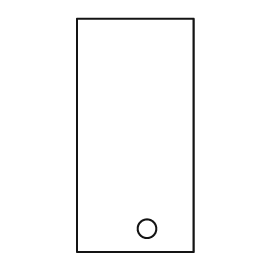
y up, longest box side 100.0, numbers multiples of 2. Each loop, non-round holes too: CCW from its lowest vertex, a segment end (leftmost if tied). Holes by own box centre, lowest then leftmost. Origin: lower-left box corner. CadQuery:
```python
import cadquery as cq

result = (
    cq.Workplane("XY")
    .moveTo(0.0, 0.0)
    .lineTo(50.0, 0.0)
    .lineTo(50.0, 100.0)
    .lineTo(0.0, 100.0)
    .close()
    .moveTo(30.0, 10.0)
    .circle(4.0)
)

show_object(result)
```